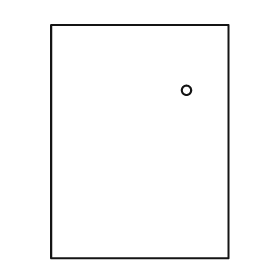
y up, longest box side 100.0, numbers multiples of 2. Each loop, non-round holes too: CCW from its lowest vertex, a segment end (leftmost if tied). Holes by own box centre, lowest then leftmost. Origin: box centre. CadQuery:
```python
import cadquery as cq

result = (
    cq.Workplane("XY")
    .moveTo(-38.0, -50.0)
    .lineTo(38.0, -50.0)
    .lineTo(38.0, 50.0)
    .lineTo(-38.0, 50.0)
    .close()
    .moveTo(20.0, 22.0)
    .circle(2.0)
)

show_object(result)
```